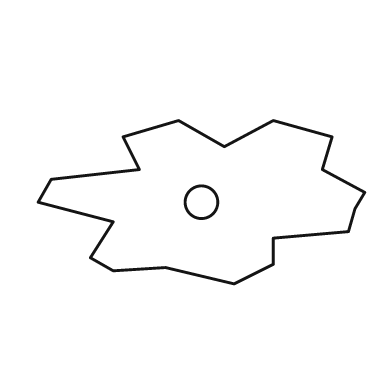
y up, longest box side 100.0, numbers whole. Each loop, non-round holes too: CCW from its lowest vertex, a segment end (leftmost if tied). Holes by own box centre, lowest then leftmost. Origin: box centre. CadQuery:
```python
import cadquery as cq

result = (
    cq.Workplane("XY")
    .moveTo(10.0, -25.0)
    .lineTo(22.0, -19.0)
    .lineTo(22.0, -11.0)
    .lineTo(45.0, -9.0)
    .lineTo(47.0, -2.0)
    .lineTo(50.0, 3.0)
    .lineTo(37.0, 10.0)
    .lineTo(40.0, 20.0)
    .lineTo(22.0, 25.0)
    .lineTo(7.0, 17.0)
    .lineTo(-7.0, 25.0)
    .lineTo(-24.0, 20.0)
    .lineTo(-19.0, 10.0)
    .lineTo(-46.0, 7.0)
    .lineTo(-50.0, 0.0)
    .lineTo(-27.0, -6.0)
    .lineTo(-34.0, -17.0)
    .lineTo(-27.0, -21.0)
    .lineTo(-11.0, -20.0)
    .close()
    .moveTo(0.0, 0.0)
    .circle(5.0)
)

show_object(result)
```